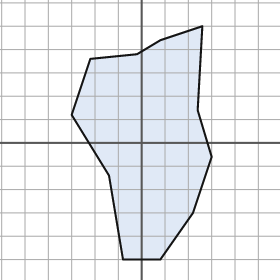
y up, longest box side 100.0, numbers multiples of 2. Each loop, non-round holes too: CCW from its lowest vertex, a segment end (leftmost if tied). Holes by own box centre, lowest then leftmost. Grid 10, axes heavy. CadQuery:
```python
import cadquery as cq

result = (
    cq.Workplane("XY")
    .moveTo(-8.0, -50.0)
    .lineTo(8.0, -50.0)
    .lineTo(22.0, -30.0)
    .lineTo(30.0, -6.0)
    .lineTo(24.0, 14.0)
    .lineTo(26.0, 50.0)
    .lineTo(8.0, 44.0)
    .lineTo(-2.0, 38.0)
    .lineTo(-22.0, 36.0)
    .lineTo(-30.0, 12.0)
    .lineTo(-14.0, -14.0)
    .close()
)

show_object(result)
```